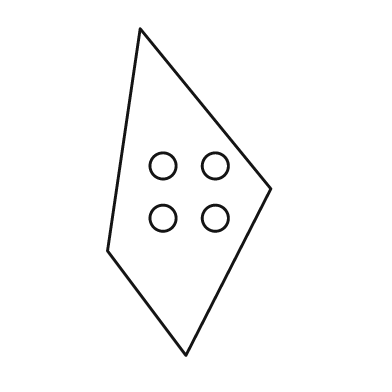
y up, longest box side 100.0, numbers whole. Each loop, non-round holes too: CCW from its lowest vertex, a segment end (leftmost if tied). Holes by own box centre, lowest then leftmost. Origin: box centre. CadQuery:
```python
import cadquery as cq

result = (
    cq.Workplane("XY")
    .moveTo(-1.0, -50.0)
    .lineTo(25.0, 1.0)
    .lineTo(-15.0, 50.0)
    .lineTo(-25.0, -18.0)
    .close()
    .moveTo(-8.0, -8.0)
    .circle(4.0)
    .moveTo(8.0, -8.0)
    .circle(4.0)
    .moveTo(-8.0, 8.0)
    .circle(4.0)
    .moveTo(8.0, 8.0)
    .circle(4.0)
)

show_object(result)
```